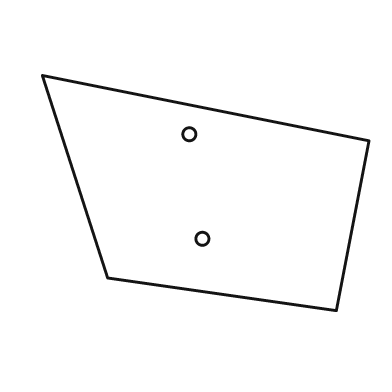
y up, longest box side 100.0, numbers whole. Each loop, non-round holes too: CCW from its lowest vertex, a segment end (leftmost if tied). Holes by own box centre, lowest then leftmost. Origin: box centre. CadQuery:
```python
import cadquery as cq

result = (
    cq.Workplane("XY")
    .moveTo(40.0, -36.0)
    .lineTo(50.0, 16.0)
    .lineTo(-50.0, 36.0)
    .lineTo(-30.0, -26.0)
    .close()
    .moveTo(-1.0, -14.0)
    .circle(2.0)
    .moveTo(-5.0, 18.0)
    .circle(2.0)
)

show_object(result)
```